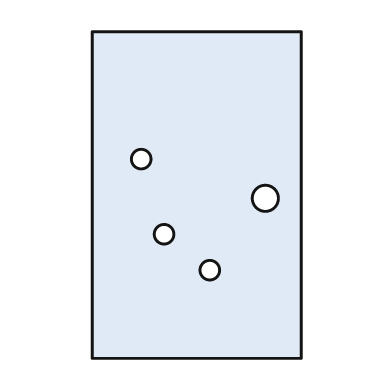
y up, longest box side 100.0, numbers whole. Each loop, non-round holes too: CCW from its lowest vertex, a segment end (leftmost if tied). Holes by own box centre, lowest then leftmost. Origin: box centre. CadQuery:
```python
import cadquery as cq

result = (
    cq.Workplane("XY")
    .moveTo(-32.0, -50.0)
    .lineTo(32.0, -50.0)
    .lineTo(32.0, 50.0)
    .lineTo(-32.0, 50.0)
    .close()
    .moveTo(4.0, -23.0)
    .circle(3.0)
    .moveTo(-10.0, -12.0)
    .circle(3.0)
    .moveTo(21.0, -1.0)
    .circle(4.0)
    .moveTo(-17.0, 11.0)
    .circle(3.0)
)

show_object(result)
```